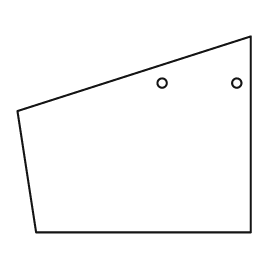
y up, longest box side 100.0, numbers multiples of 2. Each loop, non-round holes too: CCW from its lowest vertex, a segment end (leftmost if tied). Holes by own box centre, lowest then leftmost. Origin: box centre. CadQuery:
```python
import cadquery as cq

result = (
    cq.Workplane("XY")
    .moveTo(-42.0, -42.0)
    .lineTo(50.0, -42.0)
    .lineTo(50.0, 42.0)
    .lineTo(-50.0, 10.0)
    .close()
    .moveTo(12.0, 22.0)
    .circle(2.0)
    .moveTo(44.0, 22.0)
    .circle(2.0)
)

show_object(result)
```